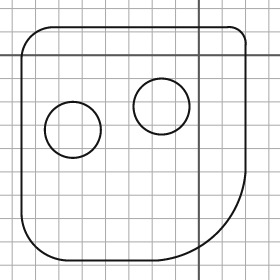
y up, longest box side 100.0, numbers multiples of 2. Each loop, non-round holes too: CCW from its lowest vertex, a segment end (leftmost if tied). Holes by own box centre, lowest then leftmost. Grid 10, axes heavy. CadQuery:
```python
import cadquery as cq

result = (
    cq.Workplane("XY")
    .moveTo(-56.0, -88.0)
    .lineTo(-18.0, -88.0)
    .threePointArc((8.0, -76.0), (20.0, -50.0))
    .lineTo(20.0, 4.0)
    .threePointArc((18.0, 10.0), (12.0, 12.0))
    .lineTo(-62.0, 12.0)
    .threePointArc((-72.0, 8.0), (-76.0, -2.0))
    .lineTo(-76.0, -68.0)
    .threePointArc((-70.0, -82.0), (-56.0, -88.0))
    .close()
    .moveTo(-54.0, -32.0)
    .circle(12.0)
    .moveTo(-16.0, -22.0)
    .circle(12.0)
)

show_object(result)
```